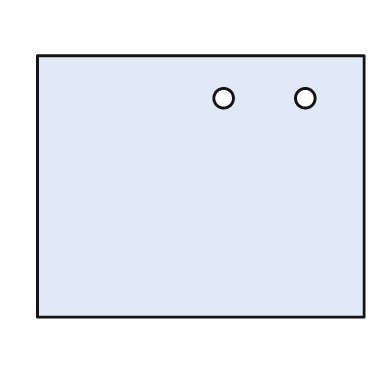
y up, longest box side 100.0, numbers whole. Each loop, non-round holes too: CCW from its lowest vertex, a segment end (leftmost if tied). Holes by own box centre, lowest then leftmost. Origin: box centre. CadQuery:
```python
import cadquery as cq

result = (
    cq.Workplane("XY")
    .moveTo(-50.0, -40.0)
    .lineTo(50.0, -40.0)
    .lineTo(50.0, 40.0)
    .lineTo(-50.0, 40.0)
    .close()
    .moveTo(7.0, 27.0)
    .circle(3.0)
    .moveTo(32.0, 27.0)
    .circle(3.0)
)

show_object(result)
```